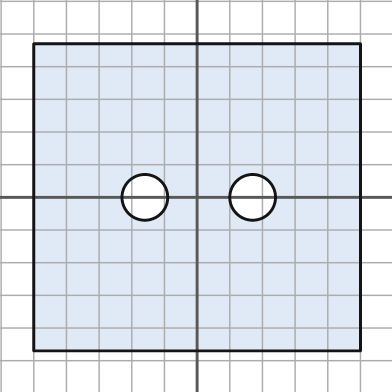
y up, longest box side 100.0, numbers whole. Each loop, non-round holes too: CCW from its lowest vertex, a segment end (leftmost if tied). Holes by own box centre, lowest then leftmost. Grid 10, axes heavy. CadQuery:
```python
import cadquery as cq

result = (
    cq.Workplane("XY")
    .moveTo(-50.0, -47.0)
    .lineTo(50.0, -47.0)
    .lineTo(50.0, 47.0)
    .lineTo(-50.0, 47.0)
    .close()
    .moveTo(-16.0, 0.0)
    .circle(7.0)
    .moveTo(17.0, 0.0)
    .circle(7.0)
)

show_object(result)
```